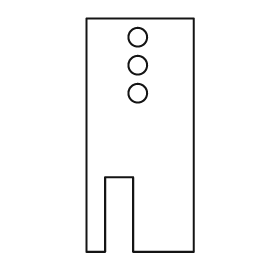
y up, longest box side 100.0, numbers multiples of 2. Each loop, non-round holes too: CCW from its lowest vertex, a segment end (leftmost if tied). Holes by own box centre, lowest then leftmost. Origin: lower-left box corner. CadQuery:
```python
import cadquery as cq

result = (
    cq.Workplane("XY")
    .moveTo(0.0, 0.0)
    .lineTo(8.0, 0.0)
    .lineTo(8.0, 32.0)
    .lineTo(20.0, 32.0)
    .lineTo(20.0, 0.0)
    .lineTo(46.0, 0.0)
    .lineTo(46.0, 100.0)
    .lineTo(0.0, 100.0)
    .close()
    .moveTo(22.0, 68.0)
    .circle(4.0)
    .moveTo(22.0, 80.0)
    .circle(4.0)
    .moveTo(22.0, 92.0)
    .circle(4.0)
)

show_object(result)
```